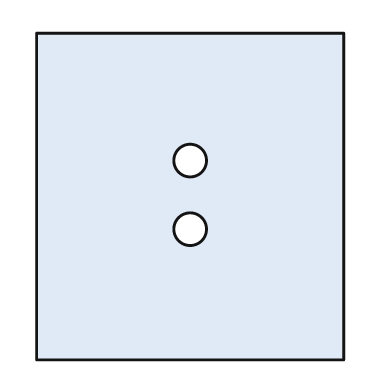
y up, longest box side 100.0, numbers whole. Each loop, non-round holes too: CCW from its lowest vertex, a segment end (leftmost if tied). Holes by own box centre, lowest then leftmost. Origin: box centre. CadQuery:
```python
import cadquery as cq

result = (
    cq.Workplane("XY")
    .moveTo(-47.0, -50.0)
    .lineTo(47.0, -50.0)
    .lineTo(47.0, 50.0)
    .lineTo(-47.0, 50.0)
    .close()
    .moveTo(0.0, -10.0)
    .circle(5.0)
    .moveTo(0.0, 11.0)
    .circle(5.0)
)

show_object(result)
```